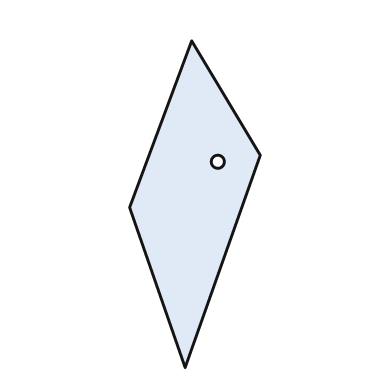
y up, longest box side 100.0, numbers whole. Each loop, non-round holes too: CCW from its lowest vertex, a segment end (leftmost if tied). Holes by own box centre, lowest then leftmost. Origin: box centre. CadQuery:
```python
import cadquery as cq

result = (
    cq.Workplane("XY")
    .moveTo(-3.0, -50.0)
    .lineTo(20.0, 15.0)
    .lineTo(-1.0, 50.0)
    .lineTo(-20.0, -1.0)
    .close()
    .moveTo(7.0, 13.0)
    .circle(2.0)
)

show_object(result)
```